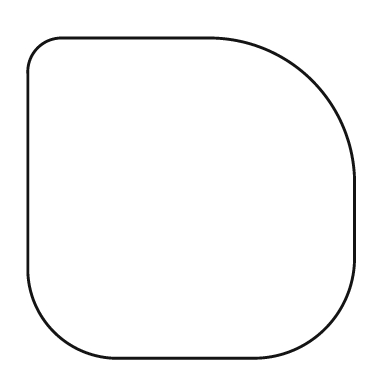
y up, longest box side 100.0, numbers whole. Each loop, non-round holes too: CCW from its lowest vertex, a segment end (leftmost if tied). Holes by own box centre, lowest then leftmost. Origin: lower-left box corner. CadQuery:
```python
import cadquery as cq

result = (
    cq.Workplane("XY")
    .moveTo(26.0, 0.0)
    .lineTo(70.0, 0.0)
    .threePointArc((91.0, 9.0), (100.0, 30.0))
    .lineTo(100.0, 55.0)
    .threePointArc((87.0, 85.0), (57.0, 98.0))
    .lineTo(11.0, 98.0)
    .threePointArc((3.0, 95.0), (0.0, 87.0))
    .lineTo(0.0, 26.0)
    .threePointArc((8.0, 8.0), (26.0, 0.0))
    .close()
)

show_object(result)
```